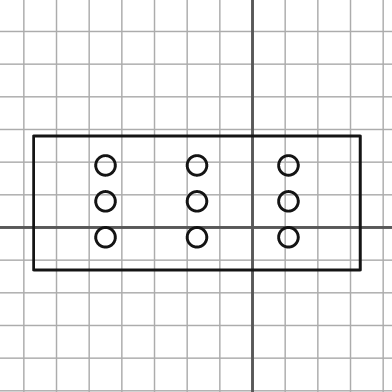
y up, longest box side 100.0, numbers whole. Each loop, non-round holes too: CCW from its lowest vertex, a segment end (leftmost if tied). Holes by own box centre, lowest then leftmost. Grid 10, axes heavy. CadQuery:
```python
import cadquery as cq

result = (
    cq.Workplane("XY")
    .moveTo(-67.0, -13.0)
    .lineTo(33.0, -13.0)
    .lineTo(33.0, 28.0)
    .lineTo(-67.0, 28.0)
    .close()
    .moveTo(-45.0, -3.0)
    .circle(3.0)
    .moveTo(-17.0, -3.0)
    .circle(3.0)
    .moveTo(11.0, -3.0)
    .circle(3.0)
    .moveTo(-45.0, 8.0)
    .circle(3.0)
    .moveTo(-17.0, 8.0)
    .circle(3.0)
    .moveTo(11.0, 8.0)
    .circle(3.0)
    .moveTo(-45.0, 19.0)
    .circle(3.0)
    .moveTo(-17.0, 19.0)
    .circle(3.0)
    .moveTo(11.0, 19.0)
    .circle(3.0)
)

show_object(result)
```